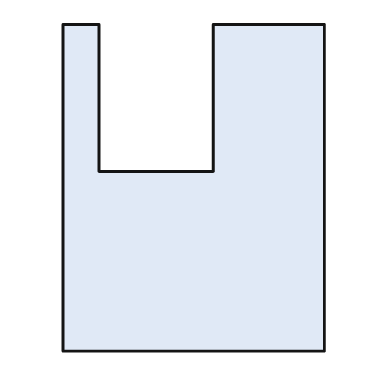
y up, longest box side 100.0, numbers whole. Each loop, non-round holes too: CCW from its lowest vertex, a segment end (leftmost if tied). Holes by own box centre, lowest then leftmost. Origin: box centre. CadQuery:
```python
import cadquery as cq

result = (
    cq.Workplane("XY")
    .moveTo(-40.0, -50.0)
    .lineTo(40.0, -50.0)
    .lineTo(40.0, 50.0)
    .lineTo(6.0, 50.0)
    .lineTo(6.0, 5.0)
    .lineTo(-29.0, 5.0)
    .lineTo(-29.0, 50.0)
    .lineTo(-40.0, 50.0)
    .close()
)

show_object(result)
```